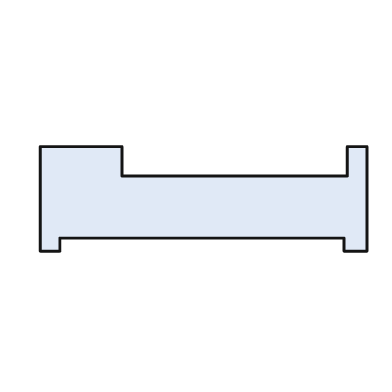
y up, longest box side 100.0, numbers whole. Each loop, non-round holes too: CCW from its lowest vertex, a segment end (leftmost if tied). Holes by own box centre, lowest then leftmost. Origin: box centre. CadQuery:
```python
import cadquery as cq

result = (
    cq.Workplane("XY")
    .moveTo(-50.0, -16.0)
    .lineTo(-44.0, -16.0)
    .lineTo(-44.0, -12.0)
    .lineTo(43.0, -12.0)
    .lineTo(43.0, -16.0)
    .lineTo(50.0, -16.0)
    .lineTo(50.0, 16.0)
    .lineTo(44.0, 16.0)
    .lineTo(44.0, 7.0)
    .lineTo(-25.0, 7.0)
    .lineTo(-25.0, 16.0)
    .lineTo(-50.0, 16.0)
    .close()
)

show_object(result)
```